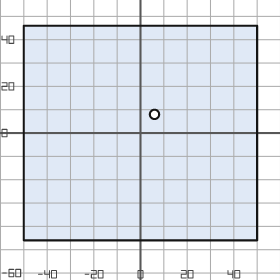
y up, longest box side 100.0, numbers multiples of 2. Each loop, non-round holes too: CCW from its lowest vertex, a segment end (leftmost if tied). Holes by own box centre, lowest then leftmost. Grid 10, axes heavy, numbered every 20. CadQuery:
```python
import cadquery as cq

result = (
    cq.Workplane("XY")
    .moveTo(-50.0, -46.0)
    .lineTo(50.0, -46.0)
    .lineTo(50.0, 46.0)
    .lineTo(-50.0, 46.0)
    .close()
    .moveTo(6.0, 8.0)
    .circle(2.0)
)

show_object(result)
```